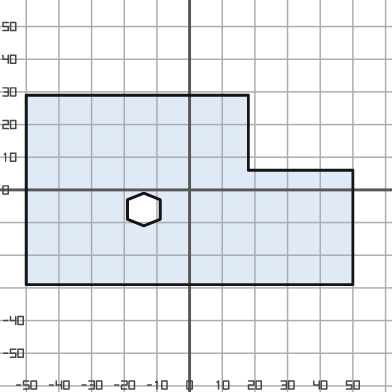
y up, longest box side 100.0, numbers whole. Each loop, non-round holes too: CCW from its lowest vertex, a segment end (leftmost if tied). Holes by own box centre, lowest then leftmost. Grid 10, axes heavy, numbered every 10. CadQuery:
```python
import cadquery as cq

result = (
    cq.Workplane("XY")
    .moveTo(-50.0, -29.0)
    .lineTo(50.0, -29.0)
    .lineTo(50.0, 6.0)
    .lineTo(18.0, 6.0)
    .lineTo(18.0, 29.0)
    .lineTo(-50.0, 29.0)
    .close()
    .moveTo(-14.0, -11.0)
    .lineTo(-9.0, -9.0)
    .lineTo(-9.0, -3.0)
    .lineTo(-14.0, -1.0)
    .lineTo(-19.0, -3.0)
    .lineTo(-19.0, -9.0)
    .close()
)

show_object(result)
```